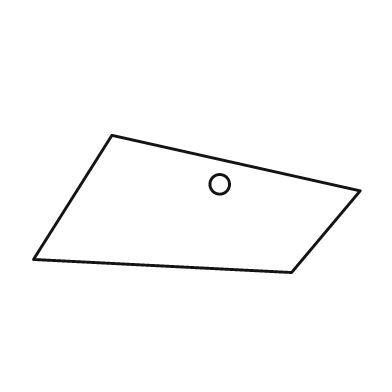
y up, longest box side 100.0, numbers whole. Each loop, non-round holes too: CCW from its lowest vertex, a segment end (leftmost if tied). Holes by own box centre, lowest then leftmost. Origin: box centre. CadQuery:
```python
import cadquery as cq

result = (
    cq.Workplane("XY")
    .moveTo(29.0, -21.0)
    .lineTo(50.0, 4.0)
    .lineTo(-26.0, 21.0)
    .lineTo(-50.0, -17.0)
    .close()
    .moveTo(7.0, 6.0)
    .circle(3.0)
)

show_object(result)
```